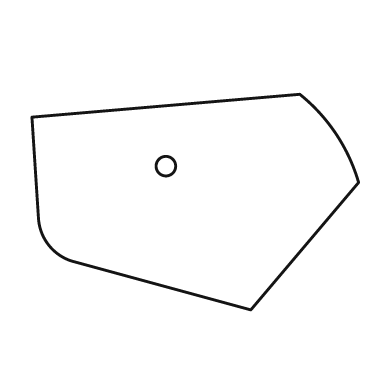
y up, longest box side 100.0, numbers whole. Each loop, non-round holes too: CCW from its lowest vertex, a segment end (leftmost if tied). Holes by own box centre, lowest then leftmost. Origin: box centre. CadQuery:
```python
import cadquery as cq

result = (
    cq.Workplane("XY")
    .moveTo(17.0, -33.0)
    .lineTo(50.0, 6.0)
    .threePointArc((43.0, 21.0), (32.0, 33.0))
    .lineTo(-50.0, 26.0)
    .lineTo(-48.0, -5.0)
    .threePointArc((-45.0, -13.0), (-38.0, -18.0))
    .close()
    .moveTo(-9.0, 11.0)
    .circle(3.0)
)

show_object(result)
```